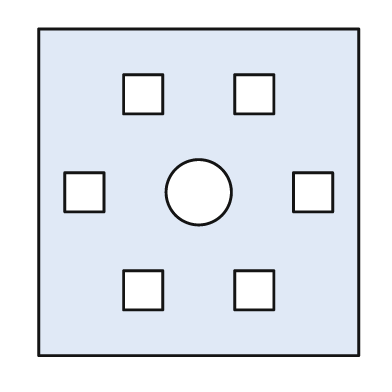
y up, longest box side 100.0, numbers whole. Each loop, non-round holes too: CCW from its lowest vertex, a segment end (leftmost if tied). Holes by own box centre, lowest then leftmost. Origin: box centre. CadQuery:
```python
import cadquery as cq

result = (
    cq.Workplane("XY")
    .moveTo(-49.0, -50.0)
    .lineTo(49.0, -50.0)
    .lineTo(49.0, 50.0)
    .lineTo(-49.0, 50.0)
    .close()
    .moveTo(-23.0, -36.0)
    .lineTo(-11.0, -36.0)
    .lineTo(-11.0, -24.0)
    .lineTo(-23.0, -24.0)
    .close()
    .moveTo(11.0, -36.0)
    .lineTo(23.0, -36.0)
    .lineTo(23.0, -24.0)
    .lineTo(11.0, -24.0)
    .close()
    .moveTo(-41.0, -6.0)
    .lineTo(-29.0, -6.0)
    .lineTo(-29.0, 6.0)
    .lineTo(-41.0, 6.0)
    .close()
    .moveTo(0.0, 0.0)
    .circle(10.0)
    .moveTo(29.0, -6.0)
    .lineTo(41.0, -6.0)
    .lineTo(41.0, 6.0)
    .lineTo(29.0, 6.0)
    .close()
    .moveTo(-23.0, 24.0)
    .lineTo(-11.0, 24.0)
    .lineTo(-11.0, 36.0)
    .lineTo(-23.0, 36.0)
    .close()
    .moveTo(11.0, 24.0)
    .lineTo(23.0, 24.0)
    .lineTo(23.0, 36.0)
    .lineTo(11.0, 36.0)
    .close()
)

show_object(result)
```